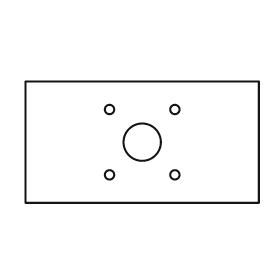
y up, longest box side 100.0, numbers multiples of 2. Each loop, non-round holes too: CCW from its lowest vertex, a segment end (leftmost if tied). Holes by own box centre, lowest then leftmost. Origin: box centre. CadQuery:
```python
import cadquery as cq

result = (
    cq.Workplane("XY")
    .moveTo(-50.0, -26.0)
    .lineTo(50.0, -26.0)
    .lineTo(50.0, 26.0)
    .lineTo(-50.0, 26.0)
    .close()
    .moveTo(-14.0, -14.0)
    .circle(2.0)
    .moveTo(14.0, -14.0)
    .circle(2.0)
    .moveTo(0.0, 0.0)
    .circle(8.0)
    .moveTo(-14.0, 14.0)
    .circle(2.0)
    .moveTo(14.0, 14.0)
    .circle(2.0)
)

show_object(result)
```